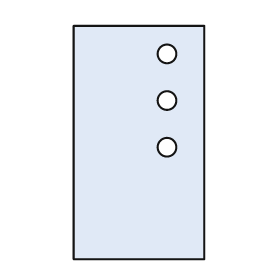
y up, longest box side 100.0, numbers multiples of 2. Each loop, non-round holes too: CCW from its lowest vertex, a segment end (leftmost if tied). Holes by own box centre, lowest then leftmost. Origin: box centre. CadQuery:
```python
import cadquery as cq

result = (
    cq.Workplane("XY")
    .moveTo(-28.0, -50.0)
    .lineTo(28.0, -50.0)
    .lineTo(28.0, 50.0)
    .lineTo(-28.0, 50.0)
    .close()
    .moveTo(12.0, -2.0)
    .circle(4.0)
    .moveTo(12.0, 18.0)
    .circle(4.0)
    .moveTo(12.0, 38.0)
    .circle(4.0)
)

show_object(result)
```